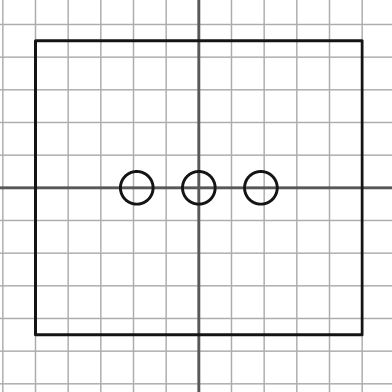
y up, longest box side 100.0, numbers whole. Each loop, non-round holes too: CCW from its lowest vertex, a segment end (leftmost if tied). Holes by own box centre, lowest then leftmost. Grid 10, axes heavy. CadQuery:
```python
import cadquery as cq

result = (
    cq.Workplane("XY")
    .moveTo(-50.0, -45.0)
    .lineTo(50.0, -45.0)
    .lineTo(50.0, 45.0)
    .lineTo(-50.0, 45.0)
    .close()
    .moveTo(-19.0, 0.0)
    .circle(5.0)
    .moveTo(0.0, 0.0)
    .circle(5.0)
    .moveTo(19.0, 0.0)
    .circle(5.0)
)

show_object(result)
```